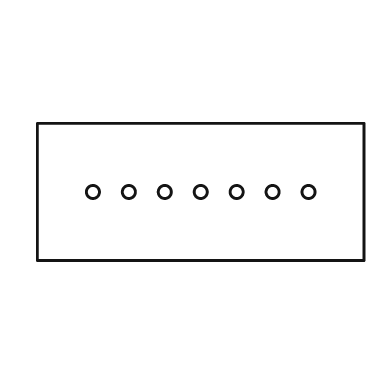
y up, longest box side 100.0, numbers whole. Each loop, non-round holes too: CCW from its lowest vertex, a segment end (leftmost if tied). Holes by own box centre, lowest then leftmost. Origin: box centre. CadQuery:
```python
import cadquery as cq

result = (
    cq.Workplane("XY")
    .moveTo(-50.0, -21.0)
    .lineTo(50.0, -21.0)
    .lineTo(50.0, 21.0)
    .lineTo(-50.0, 21.0)
    .close()
    .moveTo(-33.0, 0.0)
    .circle(2.0)
    .moveTo(-22.0, 0.0)
    .circle(2.0)
    .moveTo(-11.0, 0.0)
    .circle(2.0)
    .moveTo(0.0, 0.0)
    .circle(2.0)
    .moveTo(11.0, 0.0)
    .circle(2.0)
    .moveTo(22.0, 0.0)
    .circle(2.0)
    .moveTo(33.0, 0.0)
    .circle(2.0)
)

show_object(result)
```